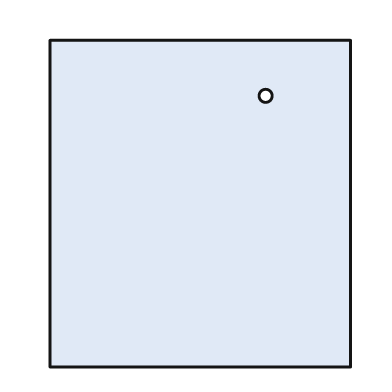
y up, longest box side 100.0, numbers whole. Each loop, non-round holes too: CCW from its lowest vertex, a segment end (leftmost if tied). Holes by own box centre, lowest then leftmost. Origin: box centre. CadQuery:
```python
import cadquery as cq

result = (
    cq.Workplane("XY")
    .moveTo(-46.0, -50.0)
    .lineTo(46.0, -50.0)
    .lineTo(46.0, 50.0)
    .lineTo(-46.0, 50.0)
    .close()
    .moveTo(20.0, 33.0)
    .circle(2.0)
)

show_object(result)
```